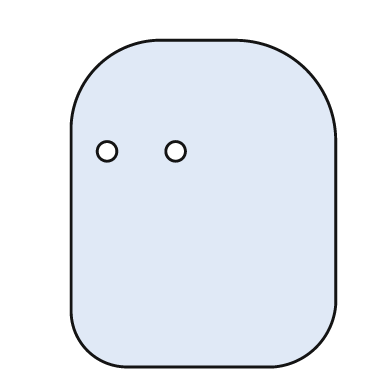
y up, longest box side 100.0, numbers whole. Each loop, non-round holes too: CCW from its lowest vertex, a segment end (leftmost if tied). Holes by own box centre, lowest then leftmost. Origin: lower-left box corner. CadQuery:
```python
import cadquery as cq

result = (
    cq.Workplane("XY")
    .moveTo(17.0, 0.0)
    .lineTo(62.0, 0.0)
    .threePointArc((75.0, 6.0), (81.0, 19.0))
    .lineTo(81.0, 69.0)
    .threePointArc((72.0, 91.0), (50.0, 100.0))
    .lineTo(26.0, 100.0)
    .threePointArc((8.0, 92.0), (0.0, 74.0))
    .lineTo(0.0, 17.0)
    .threePointArc((5.0, 5.0), (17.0, 0.0))
    .close()
    .moveTo(11.0, 66.0)
    .circle(3.0)
    .moveTo(32.0, 66.0)
    .circle(3.0)
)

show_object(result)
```